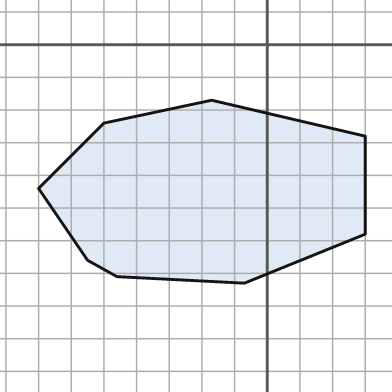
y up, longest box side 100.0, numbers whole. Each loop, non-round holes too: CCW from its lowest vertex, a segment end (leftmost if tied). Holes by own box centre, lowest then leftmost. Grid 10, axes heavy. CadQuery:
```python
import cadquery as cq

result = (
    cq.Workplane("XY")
    .moveTo(-7.0, -73.0)
    .lineTo(30.0, -58.0)
    .lineTo(30.0, -28.0)
    .lineTo(-17.0, -17.0)
    .lineTo(-50.0, -24.0)
    .lineTo(-70.0, -44.0)
    .lineTo(-55.0, -66.0)
    .lineTo(-46.0, -71.0)
    .close()
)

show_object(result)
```